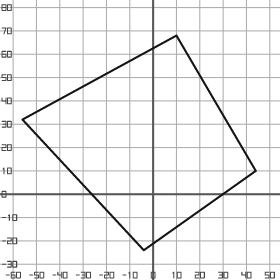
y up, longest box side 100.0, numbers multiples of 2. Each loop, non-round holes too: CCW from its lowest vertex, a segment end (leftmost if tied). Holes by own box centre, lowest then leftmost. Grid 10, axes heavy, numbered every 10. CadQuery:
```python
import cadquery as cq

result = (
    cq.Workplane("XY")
    .moveTo(-4.0, -24.0)
    .lineTo(44.0, 10.0)
    .lineTo(10.0, 68.0)
    .lineTo(-56.0, 32.0)
    .close()
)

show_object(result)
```